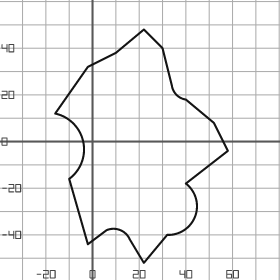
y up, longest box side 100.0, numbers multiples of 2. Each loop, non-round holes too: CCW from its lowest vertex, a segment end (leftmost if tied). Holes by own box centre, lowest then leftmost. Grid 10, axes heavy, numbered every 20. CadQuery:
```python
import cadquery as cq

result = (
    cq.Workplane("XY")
    .moveTo(22.0, -52.0)
    .lineTo(32.0, -40.0)
    .threePointArc((44.0, -32.0), (40.0, -18.0))
    .lineTo(58.0, -4.0)
    .lineTo(52.0, 8.0)
    .lineTo(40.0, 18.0)
    .threePointArc((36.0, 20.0), (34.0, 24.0))
    .lineTo(30.0, 40.0)
    .lineTo(22.0, 48.0)
    .lineTo(10.0, 38.0)
    .lineTo(-2.0, 32.0)
    .lineTo(-16.0, 12.0)
    .threePointArc((-4.0, 0.0), (-10.0, -16.0))
    .lineTo(-2.0, -44.0)
    .lineTo(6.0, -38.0)
    .threePointArc((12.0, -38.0), (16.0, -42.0))
    .close()
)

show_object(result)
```